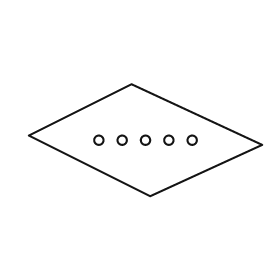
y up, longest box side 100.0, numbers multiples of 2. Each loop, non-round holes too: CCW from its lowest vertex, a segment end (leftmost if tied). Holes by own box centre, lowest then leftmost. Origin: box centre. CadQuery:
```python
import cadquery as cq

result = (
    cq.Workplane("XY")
    .moveTo(2.0, -24.0)
    .lineTo(50.0, -2.0)
    .lineTo(-6.0, 24.0)
    .lineTo(-50.0, 2.0)
    .close()
    .moveTo(-20.0, 0.0)
    .circle(2.0)
    .moveTo(-10.0, 0.0)
    .circle(2.0)
    .moveTo(0.0, 0.0)
    .circle(2.0)
    .moveTo(10.0, 0.0)
    .circle(2.0)
    .moveTo(20.0, 0.0)
    .circle(2.0)
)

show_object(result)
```